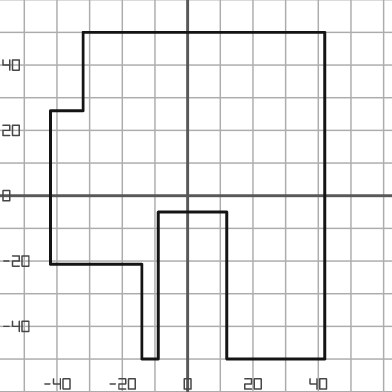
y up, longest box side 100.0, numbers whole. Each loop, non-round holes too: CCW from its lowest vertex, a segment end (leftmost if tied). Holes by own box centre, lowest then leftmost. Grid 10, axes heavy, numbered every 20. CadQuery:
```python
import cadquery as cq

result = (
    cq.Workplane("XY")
    .moveTo(-14.0, -50.0)
    .lineTo(-9.0, -50.0)
    .lineTo(-9.0, -5.0)
    .lineTo(12.0, -5.0)
    .lineTo(12.0, -50.0)
    .lineTo(42.0, -50.0)
    .lineTo(42.0, 50.0)
    .lineTo(-32.0, 50.0)
    .lineTo(-32.0, 26.0)
    .lineTo(-42.0, 26.0)
    .lineTo(-42.0, -21.0)
    .lineTo(-14.0, -21.0)
    .close()
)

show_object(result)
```